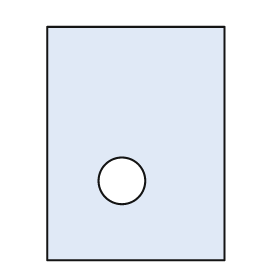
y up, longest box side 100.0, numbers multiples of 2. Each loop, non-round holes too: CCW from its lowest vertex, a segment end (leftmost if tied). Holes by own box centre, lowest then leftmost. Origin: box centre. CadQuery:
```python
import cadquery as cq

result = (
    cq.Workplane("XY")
    .moveTo(-38.0, -50.0)
    .lineTo(38.0, -50.0)
    .lineTo(38.0, 50.0)
    .lineTo(-38.0, 50.0)
    .close()
    .moveTo(-6.0, -16.0)
    .circle(10.0)
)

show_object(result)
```